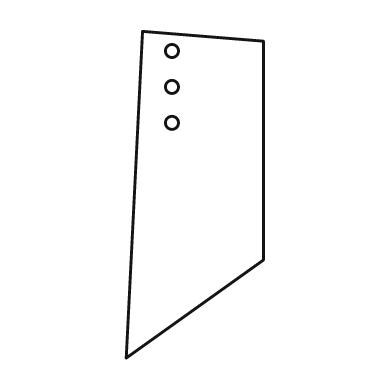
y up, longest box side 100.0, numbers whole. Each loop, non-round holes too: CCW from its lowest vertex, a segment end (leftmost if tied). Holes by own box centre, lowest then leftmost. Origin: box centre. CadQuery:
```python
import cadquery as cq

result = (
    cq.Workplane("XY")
    .moveTo(-21.0, -50.0)
    .lineTo(21.0, -20.0)
    .lineTo(21.0, 47.0)
    .lineTo(-16.0, 50.0)
    .close()
    .moveTo(-7.0, 22.0)
    .circle(2.0)
    .moveTo(-7.0, 33.0)
    .circle(2.0)
    .moveTo(-7.0, 44.0)
    .circle(2.0)
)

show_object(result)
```